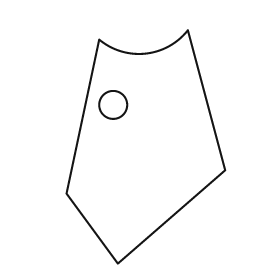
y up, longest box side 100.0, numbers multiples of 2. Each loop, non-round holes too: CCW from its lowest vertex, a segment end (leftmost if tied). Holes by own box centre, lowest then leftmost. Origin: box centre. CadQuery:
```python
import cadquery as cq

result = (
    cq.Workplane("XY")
    .moveTo(-12.0, -50.0)
    .lineTo(34.0, -10.0)
    .lineTo(18.0, 50.0)
    .threePointArc((0.0, 40.0), (-20.0, 46.0))
    .lineTo(-34.0, -20.0)
    .close()
    .moveTo(-14.0, 18.0)
    .circle(6.0)
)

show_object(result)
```